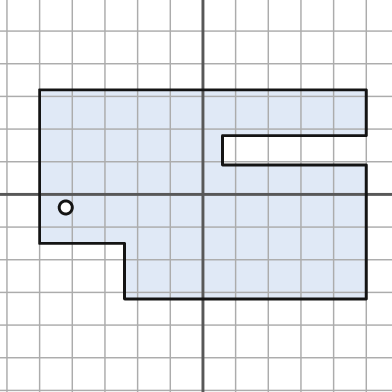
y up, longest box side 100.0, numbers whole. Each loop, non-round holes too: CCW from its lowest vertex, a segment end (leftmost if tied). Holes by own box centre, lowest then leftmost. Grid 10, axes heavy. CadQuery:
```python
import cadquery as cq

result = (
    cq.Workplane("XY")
    .moveTo(-24.0, -32.0)
    .lineTo(50.0, -32.0)
    .lineTo(50.0, 9.0)
    .lineTo(6.0, 9.0)
    .lineTo(6.0, 18.0)
    .lineTo(50.0, 18.0)
    .lineTo(50.0, 32.0)
    .lineTo(-50.0, 32.0)
    .lineTo(-50.0, -15.0)
    .lineTo(-24.0, -15.0)
    .close()
    .moveTo(-42.0, -4.0)
    .circle(2.0)
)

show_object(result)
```